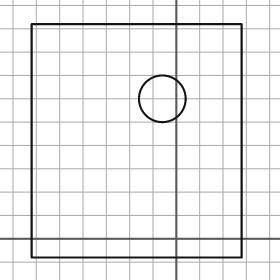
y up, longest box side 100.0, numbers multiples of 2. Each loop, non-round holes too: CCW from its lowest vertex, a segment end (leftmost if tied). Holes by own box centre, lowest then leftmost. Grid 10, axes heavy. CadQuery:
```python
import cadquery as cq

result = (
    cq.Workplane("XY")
    .moveTo(-62.0, -8.0)
    .lineTo(28.0, -8.0)
    .lineTo(28.0, 92.0)
    .lineTo(-62.0, 92.0)
    .close()
    .moveTo(-6.0, 60.0)
    .circle(10.0)
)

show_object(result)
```